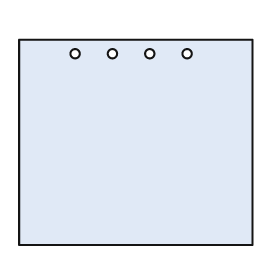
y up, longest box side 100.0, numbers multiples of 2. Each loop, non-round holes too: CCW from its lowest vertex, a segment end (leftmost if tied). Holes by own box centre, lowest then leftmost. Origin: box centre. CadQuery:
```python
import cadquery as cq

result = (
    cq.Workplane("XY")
    .moveTo(-50.0, -44.0)
    .lineTo(50.0, -44.0)
    .lineTo(50.0, 44.0)
    .lineTo(-50.0, 44.0)
    .close()
    .moveTo(-26.0, 38.0)
    .circle(2.0)
    .moveTo(-10.0, 38.0)
    .circle(2.0)
    .moveTo(6.0, 38.0)
    .circle(2.0)
    .moveTo(22.0, 38.0)
    .circle(2.0)
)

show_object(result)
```